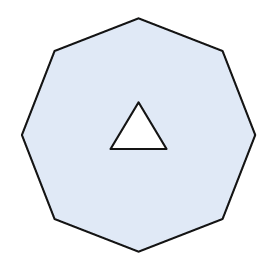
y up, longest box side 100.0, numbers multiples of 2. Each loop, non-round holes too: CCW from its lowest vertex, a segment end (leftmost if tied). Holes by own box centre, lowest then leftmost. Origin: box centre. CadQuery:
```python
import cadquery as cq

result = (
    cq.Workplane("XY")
    .moveTo(0.0, -50.0)
    .lineTo(36.0, -36.0)
    .lineTo(50.0, 0.0)
    .lineTo(36.0, 36.0)
    .lineTo(0.0, 50.0)
    .lineTo(-36.0, 36.0)
    .lineTo(-50.0, 0.0)
    .lineTo(-36.0, -36.0)
    .close()
    .moveTo(-12.0, -6.0)
    .lineTo(12.0, -6.0)
    .lineTo(0.0, 14.0)
    .close()
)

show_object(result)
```